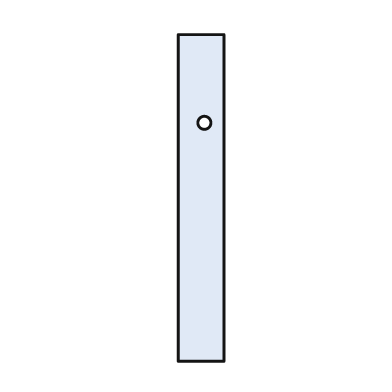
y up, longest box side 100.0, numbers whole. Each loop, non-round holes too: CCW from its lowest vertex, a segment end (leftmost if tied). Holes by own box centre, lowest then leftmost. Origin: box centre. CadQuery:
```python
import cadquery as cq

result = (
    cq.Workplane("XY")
    .moveTo(-7.0, -50.0)
    .lineTo(7.0, -50.0)
    .lineTo(7.0, 50.0)
    .lineTo(-7.0, 50.0)
    .close()
    .moveTo(1.0, 23.0)
    .circle(2.0)
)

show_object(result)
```